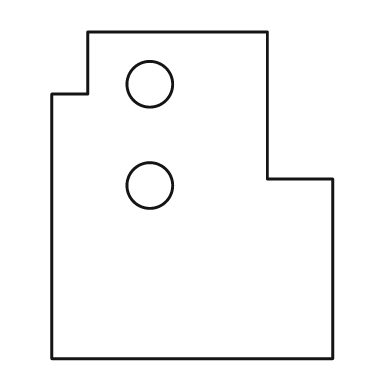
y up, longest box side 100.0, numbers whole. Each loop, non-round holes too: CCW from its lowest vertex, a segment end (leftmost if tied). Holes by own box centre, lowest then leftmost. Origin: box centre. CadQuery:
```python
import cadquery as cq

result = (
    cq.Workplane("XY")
    .moveTo(-43.0, -50.0)
    .lineTo(43.0, -50.0)
    .lineTo(43.0, 5.0)
    .lineTo(23.0, 5.0)
    .lineTo(23.0, 50.0)
    .lineTo(-32.0, 50.0)
    .lineTo(-32.0, 31.0)
    .lineTo(-43.0, 31.0)
    .close()
    .moveTo(-13.0, 3.0)
    .circle(7.0)
    .moveTo(-13.0, 34.0)
    .circle(7.0)
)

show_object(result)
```